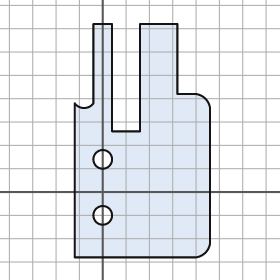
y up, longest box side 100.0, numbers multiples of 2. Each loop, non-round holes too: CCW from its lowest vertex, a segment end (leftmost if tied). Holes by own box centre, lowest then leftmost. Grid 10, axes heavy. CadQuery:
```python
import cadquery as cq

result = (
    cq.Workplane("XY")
    .moveTo(-12.0, -28.0)
    .lineTo(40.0, -28.0)
    .threePointArc((44.0, -26.0), (46.0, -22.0))
    .lineTo(46.0, 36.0)
    .threePointArc((44.0, 40.0), (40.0, 42.0))
    .lineTo(32.0, 42.0)
    .lineTo(32.0, 72.0)
    .lineTo(16.0, 72.0)
    .lineTo(16.0, 26.0)
    .lineTo(4.0, 26.0)
    .lineTo(4.0, 72.0)
    .lineTo(-4.0, 72.0)
    .lineTo(-4.0, 38.0)
    .threePointArc((-8.0, 36.0), (-12.0, 38.0))
    .close()
    .moveTo(0.0, -10.0)
    .circle(4.0)
    .moveTo(0.0, 14.0)
    .circle(4.0)
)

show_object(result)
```